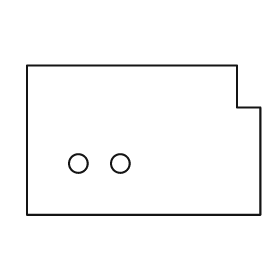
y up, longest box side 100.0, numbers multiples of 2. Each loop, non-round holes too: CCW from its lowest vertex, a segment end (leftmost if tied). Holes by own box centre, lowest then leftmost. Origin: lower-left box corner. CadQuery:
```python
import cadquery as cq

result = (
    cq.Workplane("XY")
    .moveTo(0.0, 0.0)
    .lineTo(100.0, 0.0)
    .lineTo(100.0, 46.0)
    .lineTo(90.0, 46.0)
    .lineTo(90.0, 64.0)
    .lineTo(0.0, 64.0)
    .close()
    .moveTo(22.0, 22.0)
    .circle(4.0)
    .moveTo(40.0, 22.0)
    .circle(4.0)
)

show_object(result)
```